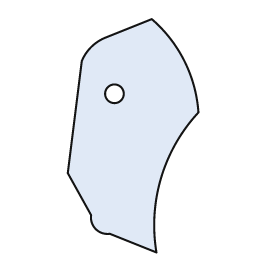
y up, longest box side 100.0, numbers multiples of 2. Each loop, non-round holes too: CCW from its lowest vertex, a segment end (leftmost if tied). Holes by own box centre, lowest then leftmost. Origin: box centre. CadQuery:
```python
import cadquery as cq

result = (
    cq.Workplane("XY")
    .moveTo(10.0, -50.0)
    .threePointArc((12.0, -18.0), (28.0, 10.0))
    .threePointArc((22.0, 32.0), (8.0, 50.0))
    .lineTo(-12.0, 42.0)
    .threePointArc((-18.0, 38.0), (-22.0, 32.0))
    .lineTo(-28.0, -16.0)
    .lineTo(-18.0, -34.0)
    .threePointArc((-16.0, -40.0), (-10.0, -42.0))
    .close()
    .moveTo(-8.0, 18.0)
    .circle(4.0)
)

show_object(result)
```